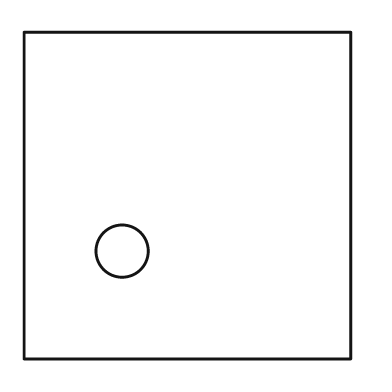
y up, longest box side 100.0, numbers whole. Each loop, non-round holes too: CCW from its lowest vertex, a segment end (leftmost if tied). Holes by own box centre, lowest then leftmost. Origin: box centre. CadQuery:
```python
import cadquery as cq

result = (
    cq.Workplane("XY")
    .moveTo(-50.0, -50.0)
    .lineTo(50.0, -50.0)
    .lineTo(50.0, 50.0)
    .lineTo(-50.0, 50.0)
    .close()
    .moveTo(-20.0, -17.0)
    .circle(8.0)
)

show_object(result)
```